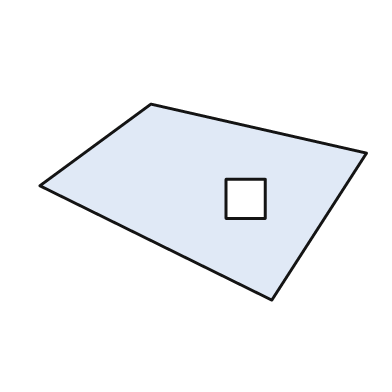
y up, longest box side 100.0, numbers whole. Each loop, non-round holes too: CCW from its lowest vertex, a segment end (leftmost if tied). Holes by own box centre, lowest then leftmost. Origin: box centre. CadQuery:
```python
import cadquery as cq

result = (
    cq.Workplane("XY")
    .moveTo(21.0, -30.0)
    .lineTo(50.0, 15.0)
    .lineTo(-16.0, 30.0)
    .lineTo(-50.0, 5.0)
    .close()
    .moveTo(7.0, -5.0)
    .lineTo(19.0, -5.0)
    .lineTo(19.0, 7.0)
    .lineTo(7.0, 7.0)
    .close()
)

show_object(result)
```